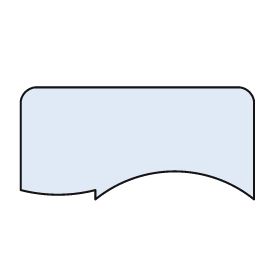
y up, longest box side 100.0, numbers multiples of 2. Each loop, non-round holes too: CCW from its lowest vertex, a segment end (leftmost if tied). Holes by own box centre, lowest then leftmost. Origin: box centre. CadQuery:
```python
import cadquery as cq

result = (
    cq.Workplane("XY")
    .moveTo(-18.0, -24.0)
    .threePointArc((16.0, -12.0), (50.0, -24.0))
    .lineTo(50.0, 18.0)
    .threePointArc((48.0, 22.0), (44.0, 24.0))
    .lineTo(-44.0, 24.0)
    .threePointArc((-48.0, 22.0), (-50.0, 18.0))
    .lineTo(-50.0, -20.0)
    .threePointArc((-34.0, -22.0), (-18.0, -20.0))
    .close()
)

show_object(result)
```